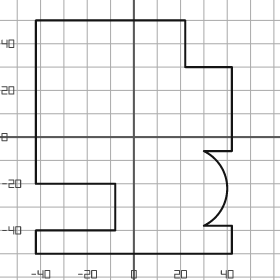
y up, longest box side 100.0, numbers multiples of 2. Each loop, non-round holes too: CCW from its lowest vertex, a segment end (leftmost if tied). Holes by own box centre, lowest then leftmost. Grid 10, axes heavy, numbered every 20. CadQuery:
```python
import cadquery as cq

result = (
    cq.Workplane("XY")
    .moveTo(-42.0, -50.0)
    .lineTo(42.0, -50.0)
    .lineTo(42.0, -38.0)
    .lineTo(30.0, -38.0)
    .threePointArc((40.0, -22.0), (30.0, -6.0))
    .lineTo(42.0, -6.0)
    .lineTo(42.0, 30.0)
    .lineTo(22.0, 30.0)
    .lineTo(22.0, 50.0)
    .lineTo(-42.0, 50.0)
    .lineTo(-42.0, -20.0)
    .lineTo(-8.0, -20.0)
    .lineTo(-8.0, -40.0)
    .lineTo(-42.0, -40.0)
    .close()
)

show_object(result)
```